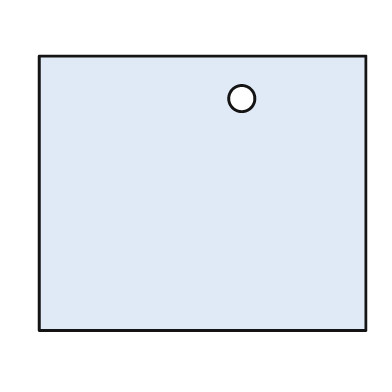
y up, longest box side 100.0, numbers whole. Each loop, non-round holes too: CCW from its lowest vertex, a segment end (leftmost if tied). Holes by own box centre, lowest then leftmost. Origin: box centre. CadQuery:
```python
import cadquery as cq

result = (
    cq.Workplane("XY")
    .moveTo(-50.0, -42.0)
    .lineTo(50.0, -42.0)
    .lineTo(50.0, 42.0)
    .lineTo(-50.0, 42.0)
    .close()
    .moveTo(12.0, 29.0)
    .circle(4.0)
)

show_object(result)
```